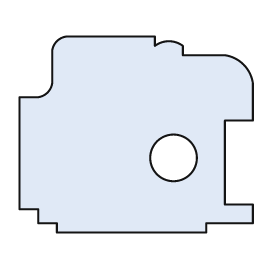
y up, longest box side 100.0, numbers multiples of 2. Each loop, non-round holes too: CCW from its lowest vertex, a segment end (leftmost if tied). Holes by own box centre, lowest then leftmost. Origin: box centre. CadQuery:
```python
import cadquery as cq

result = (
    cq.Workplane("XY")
    .moveTo(-34.0, -42.0)
    .lineTo(30.0, -42.0)
    .lineTo(30.0, -38.0)
    .lineTo(50.0, -38.0)
    .lineTo(50.0, -30.0)
    .lineTo(38.0, -30.0)
    .lineTo(38.0, 6.0)
    .lineTo(50.0, 6.0)
    .lineTo(50.0, 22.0)
    .threePointArc((46.0, 30.0), (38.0, 34.0))
    .lineTo(20.0, 34.0)
    .lineTo(20.0, 38.0)
    .threePointArc((14.0, 40.0), (8.0, 38.0))
    .lineTo(8.0, 42.0)
    .lineTo(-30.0, 42.0)
    .threePointArc((-34.0, 40.0), (-36.0, 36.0))
    .lineTo(-36.0, 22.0)
    .threePointArc((-38.0, 18.0), (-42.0, 16.0))
    .lineTo(-50.0, 16.0)
    .lineTo(-50.0, -32.0)
    .lineTo(-42.0, -32.0)
    .lineTo(-42.0, -38.0)
    .lineTo(-34.0, -38.0)
    .close()
    .moveTo(16.0, -10.0)
    .circle(10.0)
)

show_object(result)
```